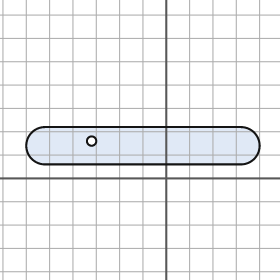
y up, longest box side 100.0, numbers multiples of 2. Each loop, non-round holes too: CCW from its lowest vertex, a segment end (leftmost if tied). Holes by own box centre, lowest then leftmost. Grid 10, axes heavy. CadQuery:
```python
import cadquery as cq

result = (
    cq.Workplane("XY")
    .moveTo(-52.0, 6.0)
    .lineTo(32.0, 6.0)
    .threePointArc((40.0, 14.0), (32.0, 22.0))
    .lineTo(-52.0, 22.0)
    .threePointArc((-60.0, 14.0), (-52.0, 6.0))
    .close()
    .moveTo(-32.0, 16.0)
    .circle(2.0)
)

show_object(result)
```